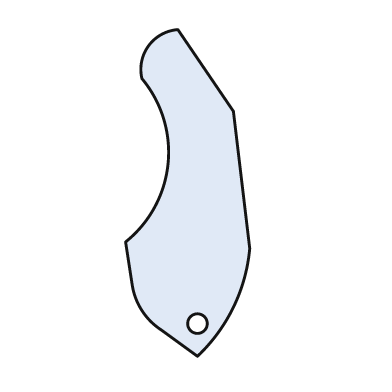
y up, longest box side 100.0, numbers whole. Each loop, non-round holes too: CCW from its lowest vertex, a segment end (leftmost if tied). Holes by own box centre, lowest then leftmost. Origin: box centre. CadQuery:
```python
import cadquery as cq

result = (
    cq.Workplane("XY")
    .moveTo(3.0, -50.0)
    .threePointArc((14.0, -35.0), (19.0, -17.0))
    .lineTo(14.0, 25.0)
    .lineTo(-3.0, 50.0)
    .threePointArc((-12.0, 45.0), (-14.0, 35.0))
    .threePointArc((-6.0, 9.0), (-19.0, -15.0))
    .lineTo(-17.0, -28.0)
    .threePointArc((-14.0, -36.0), (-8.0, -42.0))
    .close()
    .moveTo(3.0, -40.0)
    .circle(3.0)
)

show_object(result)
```